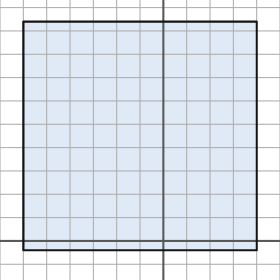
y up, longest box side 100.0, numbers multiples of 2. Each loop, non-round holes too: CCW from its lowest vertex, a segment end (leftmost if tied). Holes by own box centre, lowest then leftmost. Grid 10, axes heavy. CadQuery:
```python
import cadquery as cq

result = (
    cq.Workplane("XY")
    .moveTo(-60.0, -4.0)
    .lineTo(40.0, -4.0)
    .lineTo(40.0, 94.0)
    .lineTo(-60.0, 94.0)
    .close()
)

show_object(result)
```